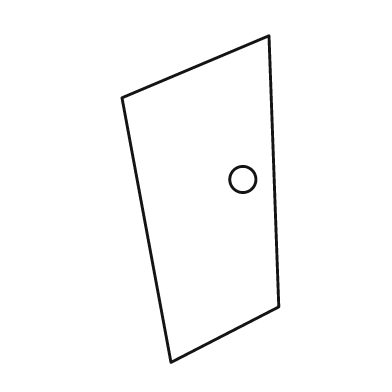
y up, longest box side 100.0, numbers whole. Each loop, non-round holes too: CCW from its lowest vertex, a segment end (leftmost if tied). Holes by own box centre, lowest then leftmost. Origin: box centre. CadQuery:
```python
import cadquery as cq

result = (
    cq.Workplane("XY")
    .moveTo(-9.0, -50.0)
    .lineTo(24.0, -33.0)
    .lineTo(21.0, 50.0)
    .lineTo(-24.0, 31.0)
    .close()
    .moveTo(13.0, 6.0)
    .circle(4.0)
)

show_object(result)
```